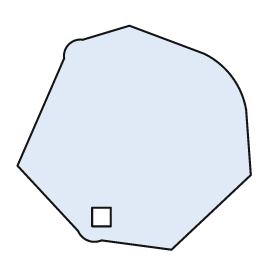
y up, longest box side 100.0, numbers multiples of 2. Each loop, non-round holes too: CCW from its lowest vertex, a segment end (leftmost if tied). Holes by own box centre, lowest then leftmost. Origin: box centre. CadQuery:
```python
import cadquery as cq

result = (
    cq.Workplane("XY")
    .moveTo(16.0, -48.0)
    .lineTo(50.0, -16.0)
    .lineTo(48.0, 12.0)
    .threePointArc((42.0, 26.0), (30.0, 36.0))
    .lineTo(-2.0, 48.0)
    .lineTo(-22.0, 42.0)
    .threePointArc((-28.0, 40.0), (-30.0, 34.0))
    .lineTo(-50.0, -12.0)
    .lineTo(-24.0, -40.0)
    .threePointArc((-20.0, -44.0), (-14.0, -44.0))
    .close()
    .moveTo(-18.0, -38.0)
    .lineTo(-10.0, -38.0)
    .lineTo(-10.0, -30.0)
    .lineTo(-18.0, -30.0)
    .close()
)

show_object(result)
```